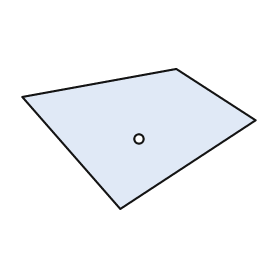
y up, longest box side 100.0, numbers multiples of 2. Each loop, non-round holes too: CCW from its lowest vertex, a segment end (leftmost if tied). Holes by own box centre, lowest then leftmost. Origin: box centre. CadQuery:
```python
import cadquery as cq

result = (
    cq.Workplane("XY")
    .moveTo(-8.0, -30.0)
    .lineTo(50.0, 8.0)
    .lineTo(16.0, 30.0)
    .lineTo(-50.0, 18.0)
    .close()
    .moveTo(0.0, 0.0)
    .circle(2.0)
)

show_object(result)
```